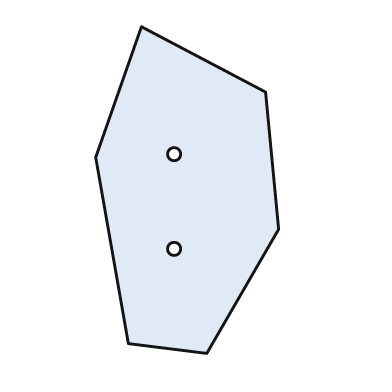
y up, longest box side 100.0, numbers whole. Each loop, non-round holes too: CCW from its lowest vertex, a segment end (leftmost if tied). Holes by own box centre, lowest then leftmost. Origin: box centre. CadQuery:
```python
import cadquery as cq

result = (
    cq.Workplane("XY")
    .moveTo(6.0, -50.0)
    .lineTo(28.0, -12.0)
    .lineTo(24.0, 30.0)
    .lineTo(-14.0, 50.0)
    .lineTo(-28.0, 10.0)
    .lineTo(-18.0, -47.0)
    .close()
    .moveTo(-4.0, -18.0)
    .circle(2.0)
    .moveTo(-4.0, 11.0)
    .circle(2.0)
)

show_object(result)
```